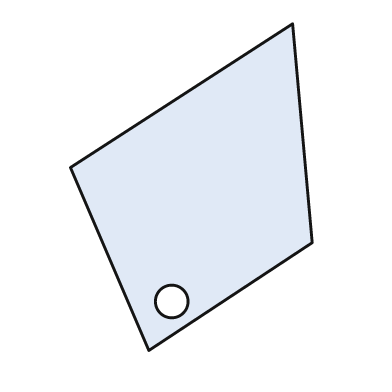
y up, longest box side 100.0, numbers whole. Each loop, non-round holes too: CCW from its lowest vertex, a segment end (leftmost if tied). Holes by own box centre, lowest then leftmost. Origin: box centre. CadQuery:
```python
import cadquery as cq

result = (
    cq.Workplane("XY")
    .moveTo(-13.0, -50.0)
    .lineTo(37.0, -17.0)
    .lineTo(31.0, 50.0)
    .lineTo(-37.0, 6.0)
    .close()
    .moveTo(-6.0, -35.0)
    .circle(5.0)
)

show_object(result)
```